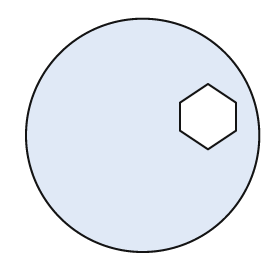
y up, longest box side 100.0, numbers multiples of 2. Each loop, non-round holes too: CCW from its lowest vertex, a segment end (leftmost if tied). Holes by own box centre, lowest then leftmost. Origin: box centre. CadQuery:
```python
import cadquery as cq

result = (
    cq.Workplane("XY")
    .moveTo(0.0, 0.0)
    .circle(50.0)
    .moveTo(28.0, -6.0)
    .lineTo(40.0, 2.0)
    .lineTo(40.0, 14.0)
    .lineTo(28.0, 22.0)
    .lineTo(16.0, 14.0)
    .lineTo(16.0, 2.0)
    .close()
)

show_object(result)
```